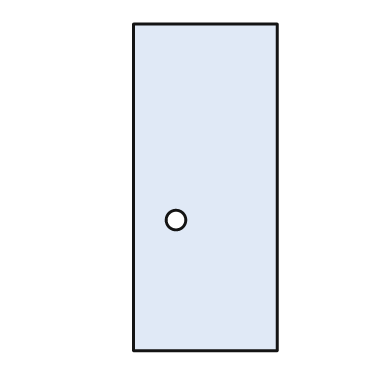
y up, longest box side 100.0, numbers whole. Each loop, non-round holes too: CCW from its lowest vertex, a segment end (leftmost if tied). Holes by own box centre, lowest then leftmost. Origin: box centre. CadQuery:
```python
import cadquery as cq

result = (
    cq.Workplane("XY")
    .moveTo(-22.0, -50.0)
    .lineTo(22.0, -50.0)
    .lineTo(22.0, 50.0)
    .lineTo(-22.0, 50.0)
    .close()
    .moveTo(-9.0, -10.0)
    .circle(3.0)
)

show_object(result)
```